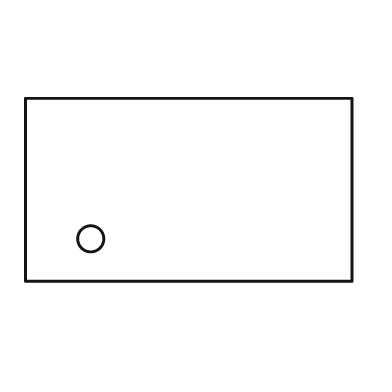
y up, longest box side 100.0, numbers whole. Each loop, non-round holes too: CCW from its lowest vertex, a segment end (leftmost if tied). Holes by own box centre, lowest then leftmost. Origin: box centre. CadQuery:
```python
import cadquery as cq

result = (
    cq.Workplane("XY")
    .moveTo(-50.0, -28.0)
    .lineTo(50.0, -28.0)
    .lineTo(50.0, 28.0)
    .lineTo(-50.0, 28.0)
    .close()
    .moveTo(-30.0, -15.0)
    .circle(4.0)
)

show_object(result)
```